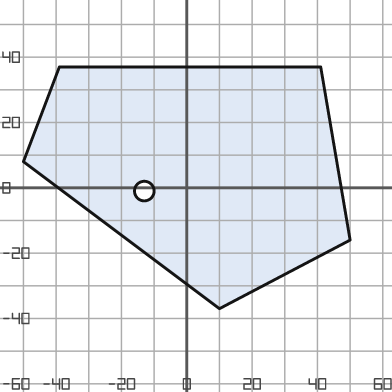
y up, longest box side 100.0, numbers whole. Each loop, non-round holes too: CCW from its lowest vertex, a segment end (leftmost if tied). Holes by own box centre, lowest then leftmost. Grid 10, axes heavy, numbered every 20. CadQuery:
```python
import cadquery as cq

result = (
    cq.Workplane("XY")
    .moveTo(10.0, -37.0)
    .lineTo(50.0, -16.0)
    .lineTo(41.0, 37.0)
    .lineTo(-39.0, 37.0)
    .lineTo(-50.0, 8.0)
    .close()
    .moveTo(-13.0, -1.0)
    .circle(3.0)
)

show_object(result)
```